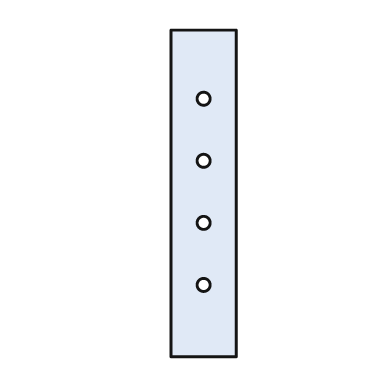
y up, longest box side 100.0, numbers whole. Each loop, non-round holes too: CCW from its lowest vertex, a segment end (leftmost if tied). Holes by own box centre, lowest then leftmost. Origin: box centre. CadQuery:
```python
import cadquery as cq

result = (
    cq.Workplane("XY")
    .moveTo(-10.0, -50.0)
    .lineTo(10.0, -50.0)
    .lineTo(10.0, 50.0)
    .lineTo(-10.0, 50.0)
    .close()
    .moveTo(0.0, -28.0)
    .circle(2.0)
    .moveTo(0.0, -9.0)
    .circle(2.0)
    .moveTo(0.0, 10.0)
    .circle(2.0)
    .moveTo(0.0, 29.0)
    .circle(2.0)
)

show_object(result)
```